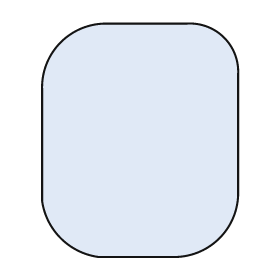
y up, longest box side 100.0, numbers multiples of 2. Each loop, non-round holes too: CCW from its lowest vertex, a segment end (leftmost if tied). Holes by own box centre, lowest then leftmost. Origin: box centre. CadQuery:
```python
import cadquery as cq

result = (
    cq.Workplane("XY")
    .moveTo(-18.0, -50.0)
    .lineTo(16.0, -50.0)
    .threePointArc((34.0, -42.0), (42.0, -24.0))
    .lineTo(42.0, 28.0)
    .threePointArc((36.0, 44.0), (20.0, 50.0))
    .lineTo(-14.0, 50.0)
    .threePointArc((-34.0, 42.0), (-42.0, 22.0))
    .lineTo(-42.0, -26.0)
    .threePointArc((-34.0, -42.0), (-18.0, -50.0))
    .close()
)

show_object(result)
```